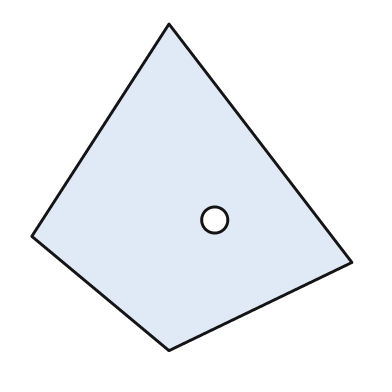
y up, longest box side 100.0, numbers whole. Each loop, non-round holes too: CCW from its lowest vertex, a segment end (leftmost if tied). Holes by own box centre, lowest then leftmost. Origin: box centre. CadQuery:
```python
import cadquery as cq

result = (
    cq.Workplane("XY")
    .moveTo(-7.0, -50.0)
    .lineTo(49.0, -23.0)
    .lineTo(-7.0, 50.0)
    .lineTo(-49.0, -15.0)
    .close()
    .moveTo(7.0, -10.0)
    .circle(4.0)
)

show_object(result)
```